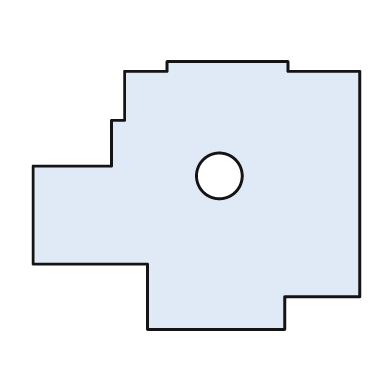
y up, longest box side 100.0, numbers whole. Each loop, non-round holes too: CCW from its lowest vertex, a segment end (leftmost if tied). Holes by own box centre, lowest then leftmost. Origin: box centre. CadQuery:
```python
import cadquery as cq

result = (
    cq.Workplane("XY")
    .moveTo(-15.0, -41.0)
    .lineTo(27.0, -41.0)
    .lineTo(27.0, -31.0)
    .lineTo(50.0, -31.0)
    .lineTo(50.0, 38.0)
    .lineTo(28.0, 38.0)
    .lineTo(28.0, 41.0)
    .lineTo(-9.0, 41.0)
    .lineTo(-9.0, 38.0)
    .lineTo(-22.0, 38.0)
    .lineTo(-22.0, 23.0)
    .lineTo(-26.0, 23.0)
    .lineTo(-26.0, 9.0)
    .lineTo(-50.0, 9.0)
    .lineTo(-50.0, -21.0)
    .lineTo(-15.0, -21.0)
    .close()
    .moveTo(7.0, 6.0)
    .circle(7.0)
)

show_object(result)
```